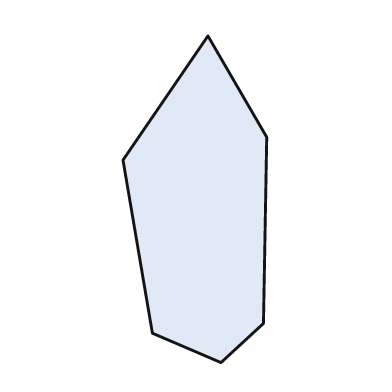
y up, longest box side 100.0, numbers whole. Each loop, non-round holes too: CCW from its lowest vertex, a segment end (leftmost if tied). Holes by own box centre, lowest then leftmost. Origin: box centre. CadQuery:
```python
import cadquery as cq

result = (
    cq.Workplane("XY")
    .moveTo(8.0, -50.0)
    .lineTo(21.0, -38.0)
    .lineTo(22.0, 19.0)
    .lineTo(4.0, 50.0)
    .lineTo(-22.0, 12.0)
    .lineTo(-13.0, -41.0)
    .close()
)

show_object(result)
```